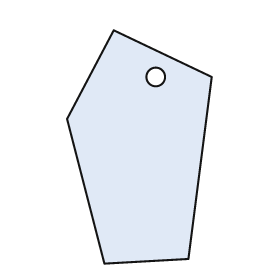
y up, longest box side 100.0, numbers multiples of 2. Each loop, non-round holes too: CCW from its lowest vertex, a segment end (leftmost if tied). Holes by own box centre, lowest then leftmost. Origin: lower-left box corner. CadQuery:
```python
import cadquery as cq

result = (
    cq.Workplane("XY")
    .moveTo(16.0, 0.0)
    .lineTo(52.0, 2.0)
    .lineTo(62.0, 80.0)
    .lineTo(20.0, 100.0)
    .lineTo(0.0, 62.0)
    .close()
    .moveTo(38.0, 80.0)
    .circle(4.0)
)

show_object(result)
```